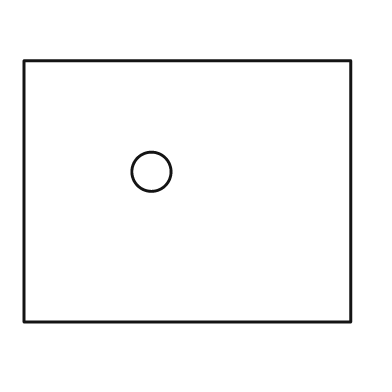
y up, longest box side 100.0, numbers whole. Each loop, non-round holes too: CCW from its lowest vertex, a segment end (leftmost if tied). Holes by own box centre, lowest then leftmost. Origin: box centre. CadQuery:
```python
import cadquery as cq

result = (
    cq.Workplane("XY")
    .moveTo(-50.0, -40.0)
    .lineTo(50.0, -40.0)
    .lineTo(50.0, 40.0)
    .lineTo(-50.0, 40.0)
    .close()
    .moveTo(-11.0, 6.0)
    .circle(6.0)
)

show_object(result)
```